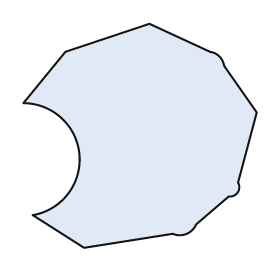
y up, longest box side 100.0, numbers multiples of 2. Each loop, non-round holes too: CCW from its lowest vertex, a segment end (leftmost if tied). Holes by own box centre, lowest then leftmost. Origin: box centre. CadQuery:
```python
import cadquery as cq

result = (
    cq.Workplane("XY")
    .moveTo(-24.0, -48.0)
    .lineTo(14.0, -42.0)
    .threePointArc((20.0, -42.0), (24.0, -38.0))
    .lineTo(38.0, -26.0)
    .threePointArc((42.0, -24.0), (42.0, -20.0))
    .lineTo(50.0, 10.0)
    .lineTo(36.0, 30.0)
    .threePointArc((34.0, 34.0), (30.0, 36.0))
    .lineTo(4.0, 48.0)
    .lineTo(-32.0, 36.0)
    .lineTo(-50.0, 14.0)
    .threePointArc((-26.0, -8.0), (-46.0, -34.0))
    .close()
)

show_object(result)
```